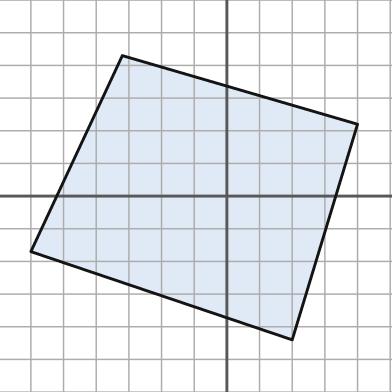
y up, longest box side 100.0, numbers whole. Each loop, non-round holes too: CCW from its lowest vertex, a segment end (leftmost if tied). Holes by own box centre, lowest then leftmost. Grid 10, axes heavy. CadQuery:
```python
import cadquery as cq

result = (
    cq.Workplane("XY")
    .moveTo(20.0, -44.0)
    .lineTo(40.0, 22.0)
    .lineTo(-32.0, 43.0)
    .lineTo(-60.0, -17.0)
    .close()
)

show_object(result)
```